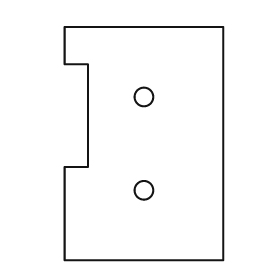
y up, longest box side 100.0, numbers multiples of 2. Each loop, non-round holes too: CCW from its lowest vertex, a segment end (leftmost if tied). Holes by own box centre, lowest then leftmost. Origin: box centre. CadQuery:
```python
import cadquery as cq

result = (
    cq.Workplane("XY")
    .moveTo(-34.0, -50.0)
    .lineTo(34.0, -50.0)
    .lineTo(34.0, 50.0)
    .lineTo(-34.0, 50.0)
    .lineTo(-34.0, 34.0)
    .lineTo(-24.0, 34.0)
    .lineTo(-24.0, -10.0)
    .lineTo(-34.0, -10.0)
    .close()
    .moveTo(0.0, -20.0)
    .circle(4.0)
    .moveTo(0.0, 20.0)
    .circle(4.0)
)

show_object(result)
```